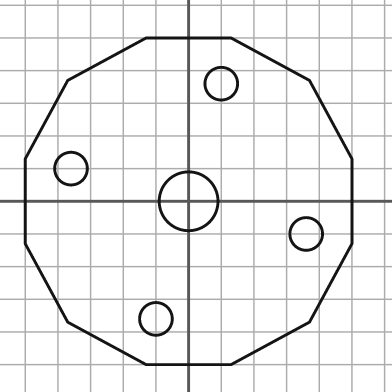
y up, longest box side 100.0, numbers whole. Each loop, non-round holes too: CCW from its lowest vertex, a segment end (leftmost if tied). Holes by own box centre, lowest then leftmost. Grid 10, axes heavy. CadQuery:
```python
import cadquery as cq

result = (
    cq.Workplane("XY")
    .moveTo(-13.0, -50.0)
    .lineTo(13.0, -50.0)
    .lineTo(37.0, -37.0)
    .lineTo(50.0, -13.0)
    .lineTo(50.0, 13.0)
    .lineTo(37.0, 37.0)
    .lineTo(13.0, 50.0)
    .lineTo(-13.0, 50.0)
    .lineTo(-37.0, 37.0)
    .lineTo(-50.0, 13.0)
    .lineTo(-50.0, -13.0)
    .lineTo(-37.0, -37.0)
    .close()
    .moveTo(-10.0, -36.0)
    .circle(5.0)
    .moveTo(36.0, -10.0)
    .circle(5.0)
    .moveTo(0.0, 0.0)
    .circle(9.0)
    .moveTo(-36.0, 10.0)
    .circle(5.0)
    .moveTo(10.0, 36.0)
    .circle(5.0)
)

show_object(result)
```